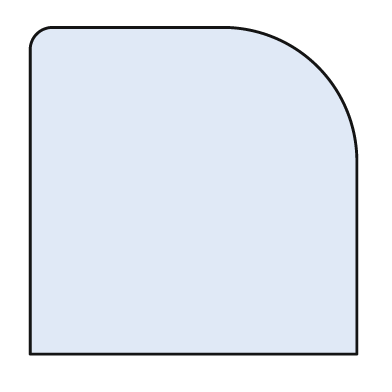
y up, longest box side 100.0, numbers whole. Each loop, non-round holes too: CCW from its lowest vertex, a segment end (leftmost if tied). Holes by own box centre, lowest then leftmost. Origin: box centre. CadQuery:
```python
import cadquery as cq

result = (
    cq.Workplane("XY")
    .moveTo(-50.0, -50.0)
    .lineTo(50.0, -50.0)
    .lineTo(50.0, 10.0)
    .threePointArc((38.0, 38.0), (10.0, 50.0))
    .lineTo(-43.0, 50.0)
    .threePointArc((-48.0, 48.0), (-50.0, 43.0))
    .close()
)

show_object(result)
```